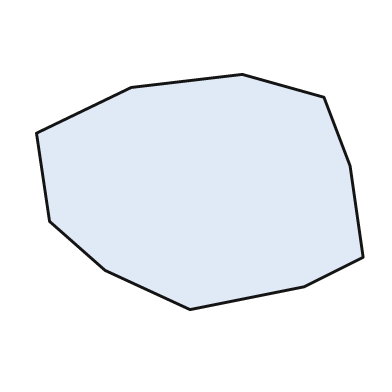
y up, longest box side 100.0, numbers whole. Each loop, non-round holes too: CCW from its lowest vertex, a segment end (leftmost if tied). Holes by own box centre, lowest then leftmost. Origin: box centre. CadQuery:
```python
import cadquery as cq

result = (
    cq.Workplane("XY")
    .moveTo(-3.0, -36.0)
    .lineTo(32.0, -29.0)
    .lineTo(50.0, -20.0)
    .lineTo(46.0, 8.0)
    .lineTo(38.0, 29.0)
    .lineTo(13.0, 36.0)
    .lineTo(-21.0, 32.0)
    .lineTo(-50.0, 18.0)
    .lineTo(-46.0, -9.0)
    .lineTo(-29.0, -24.0)
    .close()
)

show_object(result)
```